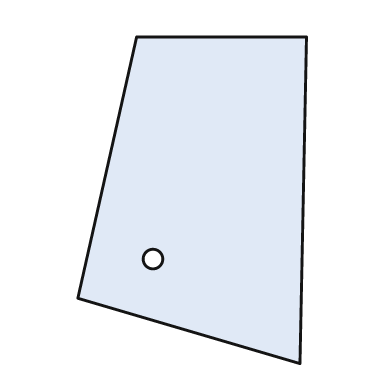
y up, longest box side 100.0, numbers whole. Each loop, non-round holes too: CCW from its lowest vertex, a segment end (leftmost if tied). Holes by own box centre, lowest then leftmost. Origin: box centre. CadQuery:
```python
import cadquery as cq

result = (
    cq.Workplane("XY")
    .moveTo(33.0, -50.0)
    .lineTo(35.0, 50.0)
    .lineTo(-17.0, 50.0)
    .lineTo(-35.0, -30.0)
    .close()
    .moveTo(-12.0, -18.0)
    .circle(3.0)
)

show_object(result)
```